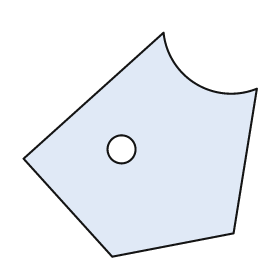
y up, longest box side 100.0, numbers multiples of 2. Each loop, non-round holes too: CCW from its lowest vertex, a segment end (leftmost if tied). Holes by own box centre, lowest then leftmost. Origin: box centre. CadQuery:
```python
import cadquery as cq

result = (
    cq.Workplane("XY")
    .moveTo(-12.0, -48.0)
    .lineTo(40.0, -38.0)
    .lineTo(50.0, 24.0)
    .threePointArc((24.0, 26.0), (10.0, 48.0))
    .lineTo(-50.0, -6.0)
    .close()
    .moveTo(-8.0, -2.0)
    .circle(6.0)
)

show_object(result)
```